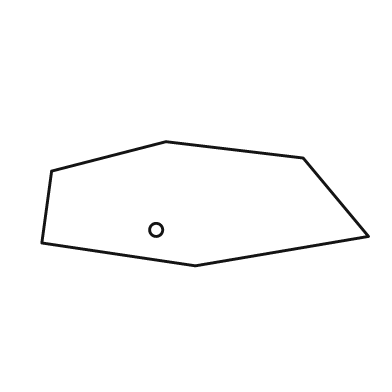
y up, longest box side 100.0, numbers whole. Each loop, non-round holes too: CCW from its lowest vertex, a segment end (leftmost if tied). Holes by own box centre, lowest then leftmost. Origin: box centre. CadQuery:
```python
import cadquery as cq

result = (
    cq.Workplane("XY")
    .moveTo(-3.0, -19.0)
    .lineTo(50.0, -10.0)
    .lineTo(30.0, 14.0)
    .lineTo(-12.0, 19.0)
    .lineTo(-47.0, 10.0)
    .lineTo(-50.0, -12.0)
    .close()
    .moveTo(-15.0, -8.0)
    .circle(2.0)
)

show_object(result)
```